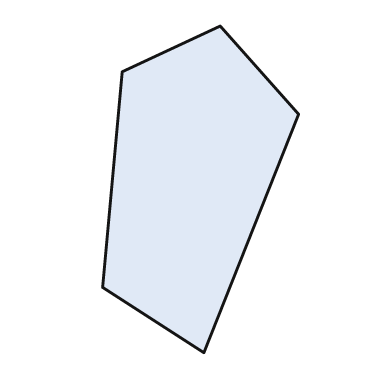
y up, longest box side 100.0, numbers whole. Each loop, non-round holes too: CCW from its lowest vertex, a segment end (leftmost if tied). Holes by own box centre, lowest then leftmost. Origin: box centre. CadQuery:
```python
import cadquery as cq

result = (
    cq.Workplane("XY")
    .moveTo(1.0, -50.0)
    .lineTo(30.0, 23.0)
    .lineTo(6.0, 50.0)
    .lineTo(-24.0, 36.0)
    .lineTo(-30.0, -30.0)
    .close()
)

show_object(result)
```